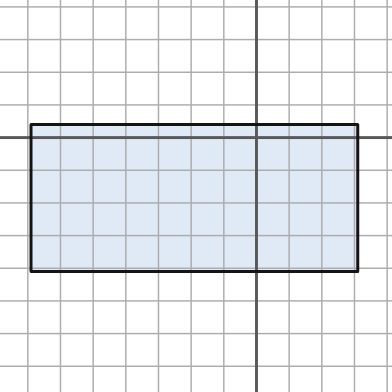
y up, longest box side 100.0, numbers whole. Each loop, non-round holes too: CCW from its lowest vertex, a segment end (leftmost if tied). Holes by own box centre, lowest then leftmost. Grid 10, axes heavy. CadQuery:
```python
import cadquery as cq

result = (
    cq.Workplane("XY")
    .moveTo(-69.0, -41.0)
    .lineTo(31.0, -41.0)
    .lineTo(31.0, 4.0)
    .lineTo(-69.0, 4.0)
    .close()
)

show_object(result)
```